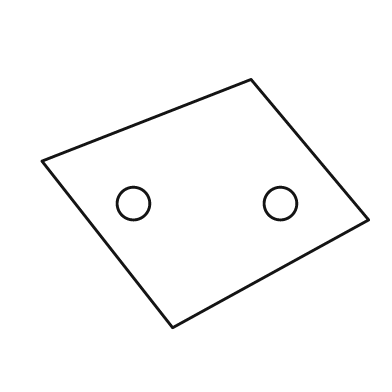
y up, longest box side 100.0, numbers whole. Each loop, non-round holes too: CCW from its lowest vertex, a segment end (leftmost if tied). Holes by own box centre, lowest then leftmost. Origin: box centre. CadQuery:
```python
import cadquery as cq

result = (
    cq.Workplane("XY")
    .moveTo(-10.0, -38.0)
    .lineTo(50.0, -5.0)
    .lineTo(14.0, 38.0)
    .lineTo(-50.0, 13.0)
    .close()
    .moveTo(-22.0, 0.0)
    .circle(5.0)
    .moveTo(23.0, 0.0)
    .circle(5.0)
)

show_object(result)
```